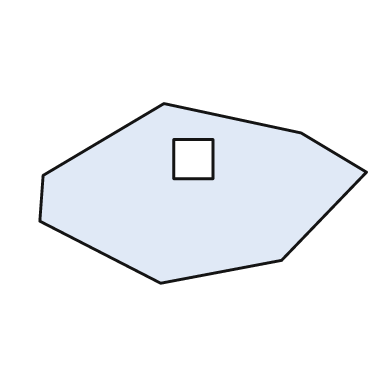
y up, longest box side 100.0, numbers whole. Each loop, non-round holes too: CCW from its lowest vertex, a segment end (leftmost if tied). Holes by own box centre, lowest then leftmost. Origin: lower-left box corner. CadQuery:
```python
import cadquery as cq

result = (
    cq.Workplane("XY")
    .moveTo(37.0, 0.0)
    .lineTo(74.0, 7.0)
    .lineTo(100.0, 34.0)
    .lineTo(80.0, 46.0)
    .lineTo(38.0, 55.0)
    .lineTo(1.0, 33.0)
    .lineTo(0.0, 19.0)
    .close()
    .moveTo(41.0, 32.0)
    .lineTo(53.0, 32.0)
    .lineTo(53.0, 44.0)
    .lineTo(41.0, 44.0)
    .close()
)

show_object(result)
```